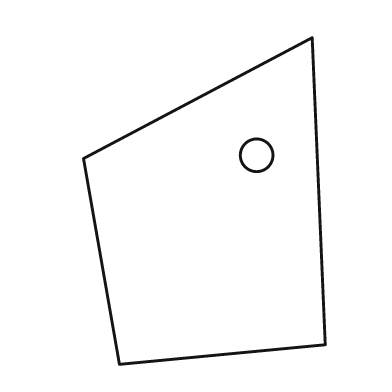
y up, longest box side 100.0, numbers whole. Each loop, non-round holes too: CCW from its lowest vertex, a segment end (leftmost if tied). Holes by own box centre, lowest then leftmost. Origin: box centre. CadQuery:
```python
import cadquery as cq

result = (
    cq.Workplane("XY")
    .moveTo(-26.0, -50.0)
    .lineTo(37.0, -44.0)
    .lineTo(33.0, 50.0)
    .lineTo(-37.0, 13.0)
    .close()
    .moveTo(16.0, 14.0)
    .circle(5.0)
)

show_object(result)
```